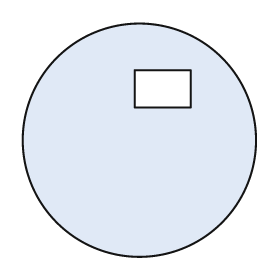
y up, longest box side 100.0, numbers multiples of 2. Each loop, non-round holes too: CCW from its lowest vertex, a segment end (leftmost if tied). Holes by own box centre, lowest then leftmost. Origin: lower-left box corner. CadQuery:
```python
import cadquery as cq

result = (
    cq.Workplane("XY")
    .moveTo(50.0, 50.0)
    .circle(50.0)
    .moveTo(48.0, 64.0)
    .lineTo(72.0, 64.0)
    .lineTo(72.0, 80.0)
    .lineTo(48.0, 80.0)
    .close()
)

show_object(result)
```